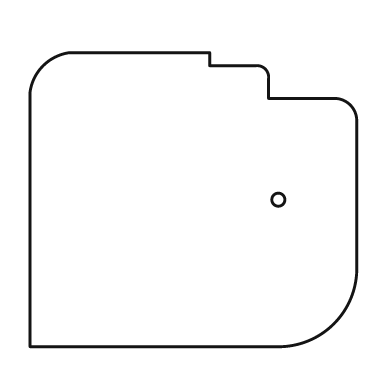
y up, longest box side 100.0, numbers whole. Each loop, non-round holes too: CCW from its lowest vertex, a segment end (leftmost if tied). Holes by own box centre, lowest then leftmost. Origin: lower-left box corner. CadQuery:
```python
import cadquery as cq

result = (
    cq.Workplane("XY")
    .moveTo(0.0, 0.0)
    .lineTo(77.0, 0.0)
    .threePointArc((93.0, 7.0), (100.0, 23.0))
    .lineTo(100.0, 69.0)
    .threePointArc((98.0, 74.0), (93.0, 76.0))
    .lineTo(73.0, 76.0)
    .lineTo(73.0, 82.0)
    .threePointArc((72.0, 85.0), (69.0, 86.0))
    .lineTo(55.0, 86.0)
    .lineTo(55.0, 90.0)
    .lineTo(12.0, 90.0)
    .threePointArc((4.0, 86.0), (0.0, 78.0))
    .close()
    .moveTo(76.0, 45.0)
    .circle(2.0)
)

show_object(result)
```